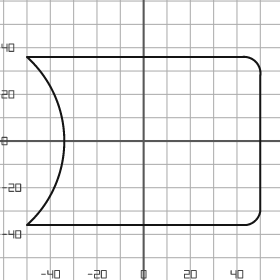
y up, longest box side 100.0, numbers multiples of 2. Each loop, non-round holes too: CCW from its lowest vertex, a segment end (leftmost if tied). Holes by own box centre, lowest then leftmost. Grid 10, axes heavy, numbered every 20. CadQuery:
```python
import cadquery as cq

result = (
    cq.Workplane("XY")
    .moveTo(-50.0, -36.0)
    .lineTo(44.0, -36.0)
    .threePointArc((48.0, -34.0), (50.0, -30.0))
    .lineTo(50.0, 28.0)
    .threePointArc((48.0, 34.0), (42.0, 36.0))
    .lineTo(-50.0, 36.0)
    .threePointArc((-34.0, 0.0), (-50.0, -36.0))
    .close()
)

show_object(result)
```